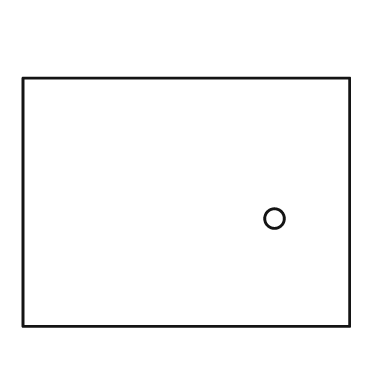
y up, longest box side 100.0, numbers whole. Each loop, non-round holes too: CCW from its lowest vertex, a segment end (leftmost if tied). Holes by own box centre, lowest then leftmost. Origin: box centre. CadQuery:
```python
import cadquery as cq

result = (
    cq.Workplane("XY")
    .moveTo(-50.0, -38.0)
    .lineTo(50.0, -38.0)
    .lineTo(50.0, 38.0)
    .lineTo(-50.0, 38.0)
    .close()
    .moveTo(27.0, -5.0)
    .circle(3.0)
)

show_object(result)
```